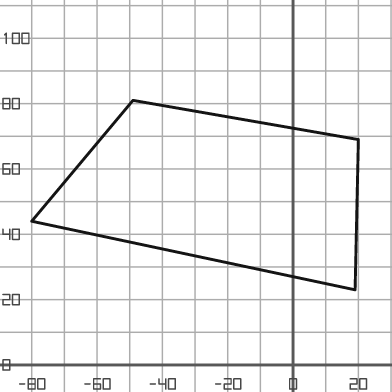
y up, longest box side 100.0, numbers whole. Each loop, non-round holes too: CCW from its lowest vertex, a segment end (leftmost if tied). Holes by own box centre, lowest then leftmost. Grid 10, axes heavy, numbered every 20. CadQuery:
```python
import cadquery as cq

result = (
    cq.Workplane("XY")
    .moveTo(19.0, 23.0)
    .lineTo(20.0, 69.0)
    .lineTo(-49.0, 81.0)
    .lineTo(-80.0, 44.0)
    .close()
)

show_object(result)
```